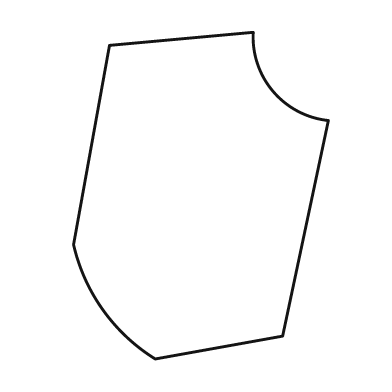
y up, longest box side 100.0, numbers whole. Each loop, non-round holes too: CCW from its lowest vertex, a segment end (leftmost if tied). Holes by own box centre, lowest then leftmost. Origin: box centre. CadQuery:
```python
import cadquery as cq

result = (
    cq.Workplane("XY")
    .moveTo(-14.0, -50.0)
    .lineTo(25.0, -43.0)
    .lineTo(39.0, 23.0)
    .threePointArc((22.0, 32.0), (16.0, 50.0))
    .lineTo(-28.0, 46.0)
    .lineTo(-39.0, -15.0)
    .threePointArc((-30.0, -35.0), (-14.0, -50.0))
    .close()
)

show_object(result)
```